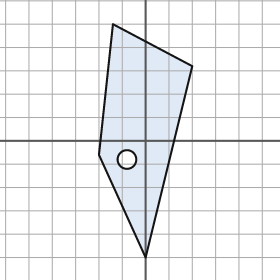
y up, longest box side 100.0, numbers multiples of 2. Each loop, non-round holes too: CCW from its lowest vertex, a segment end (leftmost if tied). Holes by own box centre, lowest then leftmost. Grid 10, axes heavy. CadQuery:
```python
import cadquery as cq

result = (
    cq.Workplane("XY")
    .moveTo(0.0, -50.0)
    .lineTo(20.0, 32.0)
    .lineTo(-14.0, 50.0)
    .lineTo(-20.0, -6.0)
    .close()
    .moveTo(-8.0, -8.0)
    .circle(4.0)
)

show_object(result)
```